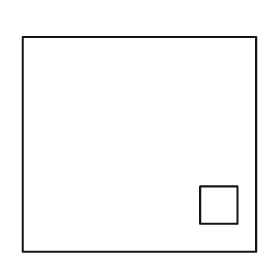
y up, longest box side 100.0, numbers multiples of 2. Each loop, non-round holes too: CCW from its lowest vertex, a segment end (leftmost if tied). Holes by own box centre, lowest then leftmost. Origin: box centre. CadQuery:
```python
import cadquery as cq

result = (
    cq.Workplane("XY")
    .moveTo(-50.0, -46.0)
    .lineTo(50.0, -46.0)
    .lineTo(50.0, 46.0)
    .lineTo(-50.0, 46.0)
    .close()
    .moveTo(26.0, -34.0)
    .lineTo(42.0, -34.0)
    .lineTo(42.0, -18.0)
    .lineTo(26.0, -18.0)
    .close()
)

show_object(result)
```